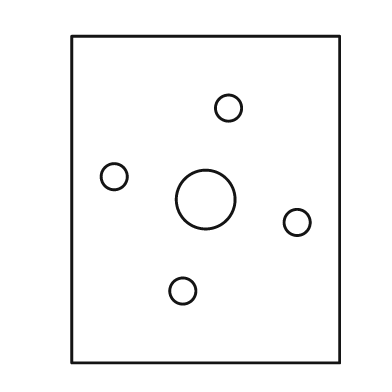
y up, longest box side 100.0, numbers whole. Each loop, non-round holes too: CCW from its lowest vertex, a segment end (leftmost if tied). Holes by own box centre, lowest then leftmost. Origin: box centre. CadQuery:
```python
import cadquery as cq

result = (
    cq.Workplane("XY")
    .moveTo(-41.0, -50.0)
    .lineTo(41.0, -50.0)
    .lineTo(41.0, 50.0)
    .lineTo(-41.0, 50.0)
    .close()
    .moveTo(-7.0, -28.0)
    .circle(4.0)
    .moveTo(28.0, -7.0)
    .circle(4.0)
    .moveTo(0.0, 0.0)
    .circle(9.0)
    .moveTo(-28.0, 7.0)
    .circle(4.0)
    .moveTo(7.0, 28.0)
    .circle(4.0)
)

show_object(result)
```